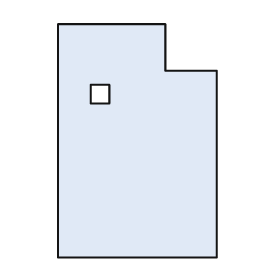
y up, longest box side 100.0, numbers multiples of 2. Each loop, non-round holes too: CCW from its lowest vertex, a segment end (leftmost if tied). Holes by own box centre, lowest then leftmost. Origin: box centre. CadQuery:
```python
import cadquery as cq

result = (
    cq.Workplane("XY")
    .moveTo(-34.0, -50.0)
    .lineTo(34.0, -50.0)
    .lineTo(34.0, 30.0)
    .lineTo(12.0, 30.0)
    .lineTo(12.0, 50.0)
    .lineTo(-34.0, 50.0)
    .close()
    .moveTo(-20.0, 16.0)
    .lineTo(-12.0, 16.0)
    .lineTo(-12.0, 24.0)
    .lineTo(-20.0, 24.0)
    .close()
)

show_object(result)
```